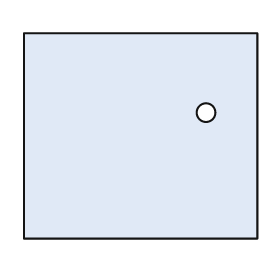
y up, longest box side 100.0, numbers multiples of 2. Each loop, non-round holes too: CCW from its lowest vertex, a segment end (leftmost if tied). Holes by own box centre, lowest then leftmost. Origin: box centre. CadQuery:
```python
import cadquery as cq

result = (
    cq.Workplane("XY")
    .moveTo(-50.0, -44.0)
    .lineTo(50.0, -44.0)
    .lineTo(50.0, 44.0)
    .lineTo(-50.0, 44.0)
    .close()
    .moveTo(28.0, 10.0)
    .circle(4.0)
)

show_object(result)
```